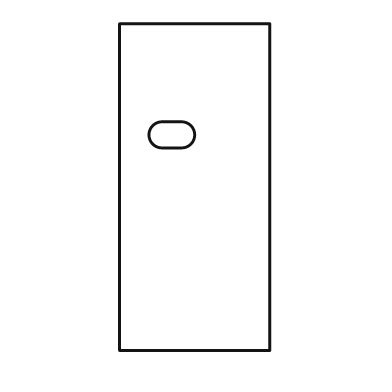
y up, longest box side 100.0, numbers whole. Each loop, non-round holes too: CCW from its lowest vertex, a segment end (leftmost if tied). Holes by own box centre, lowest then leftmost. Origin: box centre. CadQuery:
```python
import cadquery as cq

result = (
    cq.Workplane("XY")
    .moveTo(-23.0, -50.0)
    .lineTo(23.0, -50.0)
    .lineTo(23.0, 50.0)
    .lineTo(-23.0, 50.0)
    .close()
    .moveTo(-10.0, 12.0)
    .lineTo(-4.0, 12.0)
    .threePointArc((0.0, 16.0), (-4.0, 20.0))
    .lineTo(-10.0, 20.0)
    .threePointArc((-14.0, 16.0), (-10.0, 12.0))
    .close()
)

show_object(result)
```